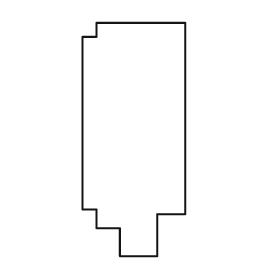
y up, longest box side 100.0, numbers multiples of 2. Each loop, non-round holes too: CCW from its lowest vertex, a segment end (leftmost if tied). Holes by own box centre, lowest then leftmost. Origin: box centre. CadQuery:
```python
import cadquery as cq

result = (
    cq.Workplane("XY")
    .moveTo(-6.0, -50.0)
    .lineTo(10.0, -50.0)
    .lineTo(10.0, -32.0)
    .lineTo(22.0, -32.0)
    .lineTo(22.0, 50.0)
    .lineTo(-16.0, 50.0)
    .lineTo(-16.0, 44.0)
    .lineTo(-22.0, 44.0)
    .lineTo(-22.0, -30.0)
    .lineTo(-16.0, -30.0)
    .lineTo(-16.0, -38.0)
    .lineTo(-6.0, -38.0)
    .close()
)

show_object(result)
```